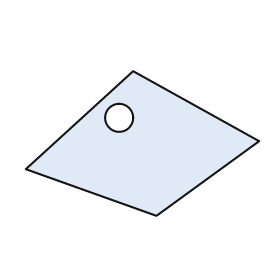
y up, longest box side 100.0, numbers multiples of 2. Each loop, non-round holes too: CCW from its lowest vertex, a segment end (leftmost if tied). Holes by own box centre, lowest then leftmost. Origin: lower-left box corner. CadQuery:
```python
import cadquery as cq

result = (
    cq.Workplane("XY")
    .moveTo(56.0, 0.0)
    .lineTo(100.0, 32.0)
    .lineTo(46.0, 62.0)
    .lineTo(0.0, 20.0)
    .close()
    .moveTo(40.0, 42.0)
    .circle(6.0)
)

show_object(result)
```